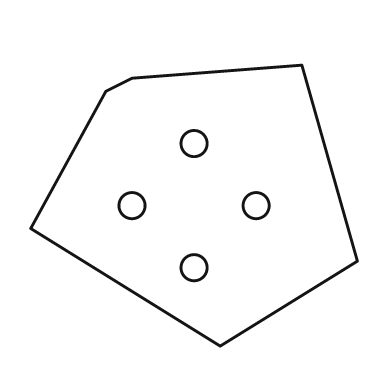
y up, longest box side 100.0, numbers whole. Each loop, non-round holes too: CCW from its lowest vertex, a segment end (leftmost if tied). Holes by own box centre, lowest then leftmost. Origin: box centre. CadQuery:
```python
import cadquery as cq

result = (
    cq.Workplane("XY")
    .moveTo(8.0, -43.0)
    .lineTo(50.0, -17.0)
    .lineTo(33.0, 43.0)
    .lineTo(-19.0, 39.0)
    .lineTo(-27.0, 35.0)
    .lineTo(-50.0, -7.0)
    .close()
    .moveTo(0.0, -19.0)
    .circle(4.0)
    .moveTo(-19.0, 0.0)
    .circle(4.0)
    .moveTo(19.0, 0.0)
    .circle(4.0)
    .moveTo(0.0, 19.0)
    .circle(4.0)
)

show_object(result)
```